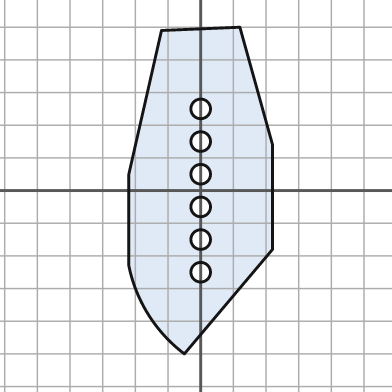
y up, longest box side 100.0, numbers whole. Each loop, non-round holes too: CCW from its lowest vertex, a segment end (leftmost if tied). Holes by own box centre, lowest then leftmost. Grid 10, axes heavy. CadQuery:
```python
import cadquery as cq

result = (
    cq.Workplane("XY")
    .moveTo(-5.0, -50.0)
    .lineTo(22.0, -18.0)
    .lineTo(22.0, 14.0)
    .lineTo(12.0, 50.0)
    .lineTo(-12.0, 49.0)
    .lineTo(-22.0, 5.0)
    .lineTo(-22.0, -23.0)
    .threePointArc((-16.0, -38.0), (-5.0, -50.0))
    .close()
    .moveTo(0.0, -25.0)
    .circle(3.0)
    .moveTo(0.0, -15.0)
    .circle(3.0)
    .moveTo(0.0, -5.0)
    .circle(3.0)
    .moveTo(0.0, 5.0)
    .circle(3.0)
    .moveTo(0.0, 15.0)
    .circle(3.0)
    .moveTo(0.0, 25.0)
    .circle(3.0)
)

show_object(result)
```